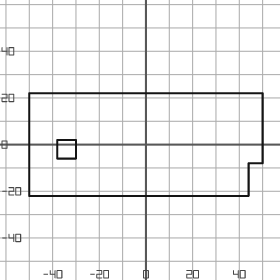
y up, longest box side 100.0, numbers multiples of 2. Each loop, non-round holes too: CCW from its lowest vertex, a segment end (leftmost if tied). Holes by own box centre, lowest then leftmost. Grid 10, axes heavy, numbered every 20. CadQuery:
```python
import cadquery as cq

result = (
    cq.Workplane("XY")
    .moveTo(-50.0, -22.0)
    .lineTo(44.0, -22.0)
    .lineTo(44.0, -8.0)
    .lineTo(50.0, -8.0)
    .lineTo(50.0, 22.0)
    .lineTo(-50.0, 22.0)
    .close()
    .moveTo(-38.0, -6.0)
    .lineTo(-30.0, -6.0)
    .lineTo(-30.0, 2.0)
    .lineTo(-38.0, 2.0)
    .close()
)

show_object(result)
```